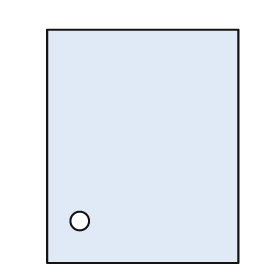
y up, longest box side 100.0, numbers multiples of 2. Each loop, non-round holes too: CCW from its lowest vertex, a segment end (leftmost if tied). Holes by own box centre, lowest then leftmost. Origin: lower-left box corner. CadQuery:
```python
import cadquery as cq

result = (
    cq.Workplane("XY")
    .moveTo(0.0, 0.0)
    .lineTo(82.0, 0.0)
    .lineTo(82.0, 100.0)
    .lineTo(0.0, 100.0)
    .close()
    .moveTo(14.0, 18.0)
    .circle(4.0)
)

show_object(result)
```